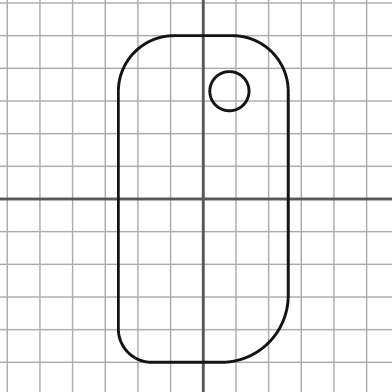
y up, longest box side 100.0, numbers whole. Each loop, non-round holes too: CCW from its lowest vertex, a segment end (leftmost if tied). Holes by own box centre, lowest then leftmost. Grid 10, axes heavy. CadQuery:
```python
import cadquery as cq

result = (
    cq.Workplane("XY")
    .moveTo(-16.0, -50.0)
    .lineTo(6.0, -50.0)
    .threePointArc((20.0, -44.0), (26.0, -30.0))
    .lineTo(26.0, 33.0)
    .threePointArc((21.0, 45.0), (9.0, 50.0))
    .lineTo(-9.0, 50.0)
    .threePointArc((-21.0, 45.0), (-26.0, 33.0))
    .lineTo(-26.0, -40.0)
    .threePointArc((-23.0, -47.0), (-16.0, -50.0))
    .close()
    .moveTo(8.0, 33.0)
    .circle(6.0)
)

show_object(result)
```